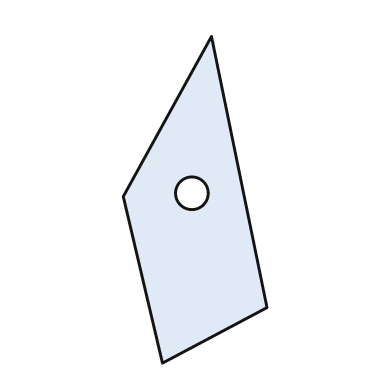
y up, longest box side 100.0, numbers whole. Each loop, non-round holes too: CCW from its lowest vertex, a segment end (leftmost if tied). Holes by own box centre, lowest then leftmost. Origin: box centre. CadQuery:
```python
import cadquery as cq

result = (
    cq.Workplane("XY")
    .moveTo(-10.0, -50.0)
    .lineTo(22.0, -33.0)
    .lineTo(5.0, 50.0)
    .lineTo(-22.0, 1.0)
    .close()
    .moveTo(-1.0, 2.0)
    .circle(5.0)
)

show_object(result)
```